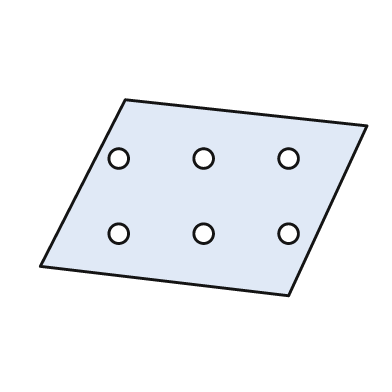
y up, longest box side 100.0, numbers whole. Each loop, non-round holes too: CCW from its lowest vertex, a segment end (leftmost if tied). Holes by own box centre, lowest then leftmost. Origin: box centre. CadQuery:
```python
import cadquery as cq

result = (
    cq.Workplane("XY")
    .moveTo(26.0, -30.0)
    .lineTo(50.0, 22.0)
    .lineTo(-24.0, 30.0)
    .lineTo(-50.0, -21.0)
    .close()
    .moveTo(-26.0, -11.0)
    .circle(3.0)
    .moveTo(0.0, -11.0)
    .circle(3.0)
    .moveTo(26.0, -11.0)
    .circle(3.0)
    .moveTo(-26.0, 12.0)
    .circle(3.0)
    .moveTo(0.0, 12.0)
    .circle(3.0)
    .moveTo(26.0, 12.0)
    .circle(3.0)
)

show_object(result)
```